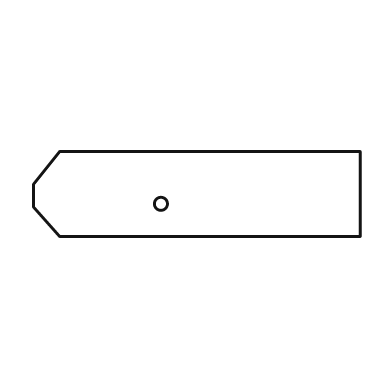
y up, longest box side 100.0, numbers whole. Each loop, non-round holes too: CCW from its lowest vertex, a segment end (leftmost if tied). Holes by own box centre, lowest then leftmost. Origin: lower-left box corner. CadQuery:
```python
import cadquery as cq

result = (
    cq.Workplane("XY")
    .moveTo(8.0, 0.0)
    .lineTo(100.0, 0.0)
    .lineTo(100.0, 26.0)
    .lineTo(8.0, 26.0)
    .lineTo(0.0, 16.0)
    .lineTo(0.0, 9.0)
    .close()
    .moveTo(39.0, 10.0)
    .circle(2.0)
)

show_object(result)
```